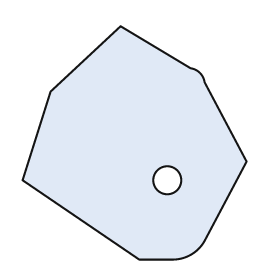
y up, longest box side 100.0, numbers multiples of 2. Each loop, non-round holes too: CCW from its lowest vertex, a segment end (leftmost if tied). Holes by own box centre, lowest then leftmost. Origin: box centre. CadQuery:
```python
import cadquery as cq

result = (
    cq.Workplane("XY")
    .moveTo(2.0, -50.0)
    .lineTo(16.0, -50.0)
    .threePointArc((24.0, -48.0), (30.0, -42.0))
    .lineTo(48.0, -8.0)
    .lineTo(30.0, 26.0)
    .threePointArc((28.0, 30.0), (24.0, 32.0))
    .lineTo(-6.0, 50.0)
    .lineTo(-36.0, 22.0)
    .lineTo(-48.0, -16.0)
    .close()
    .moveTo(14.0, -16.0)
    .circle(6.0)
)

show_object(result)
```